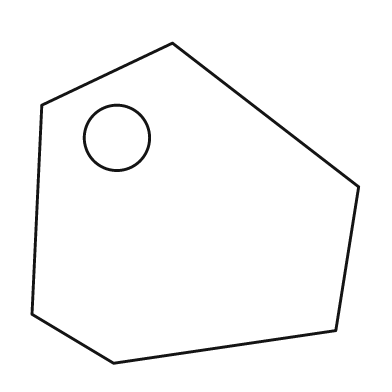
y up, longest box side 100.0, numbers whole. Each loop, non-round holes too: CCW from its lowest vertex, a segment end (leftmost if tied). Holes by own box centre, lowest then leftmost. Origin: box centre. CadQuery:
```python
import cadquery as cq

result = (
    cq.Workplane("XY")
    .moveTo(-25.0, -49.0)
    .lineTo(43.0, -39.0)
    .lineTo(50.0, 5.0)
    .lineTo(-7.0, 49.0)
    .lineTo(-47.0, 30.0)
    .lineTo(-50.0, -34.0)
    .close()
    .moveTo(-24.0, 20.0)
    .circle(10.0)
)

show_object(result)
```